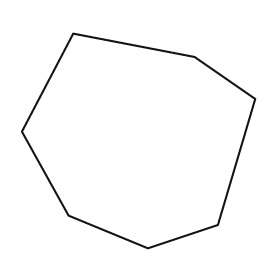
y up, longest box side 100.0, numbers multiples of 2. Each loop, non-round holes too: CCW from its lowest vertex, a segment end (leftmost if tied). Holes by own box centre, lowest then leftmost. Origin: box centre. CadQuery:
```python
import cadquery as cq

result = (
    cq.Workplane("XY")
    .moveTo(4.0, -46.0)
    .lineTo(34.0, -36.0)
    .lineTo(50.0, 18.0)
    .lineTo(24.0, 36.0)
    .lineTo(-28.0, 46.0)
    .lineTo(-50.0, 4.0)
    .lineTo(-30.0, -32.0)
    .close()
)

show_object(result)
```